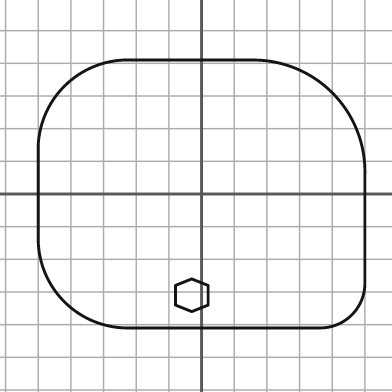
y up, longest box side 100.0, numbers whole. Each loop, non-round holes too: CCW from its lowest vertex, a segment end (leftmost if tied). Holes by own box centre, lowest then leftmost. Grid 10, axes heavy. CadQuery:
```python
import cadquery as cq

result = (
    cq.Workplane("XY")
    .moveTo(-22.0, -41.0)
    .lineTo(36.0, -41.0)
    .threePointArc((46.0, -37.0), (50.0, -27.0))
    .lineTo(50.0, 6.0)
    .threePointArc((40.0, 31.0), (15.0, 41.0))
    .lineTo(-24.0, 41.0)
    .threePointArc((-42.0, 33.0), (-50.0, 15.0))
    .lineTo(-50.0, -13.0)
    .threePointArc((-42.0, -33.0), (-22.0, -41.0))
    .close()
    .moveTo(-3.0, -36.0)
    .lineTo(2.0, -34.0)
    .lineTo(2.0, -28.0)
    .lineTo(-3.0, -26.0)
    .lineTo(-8.0, -28.0)
    .lineTo(-8.0, -34.0)
    .close()
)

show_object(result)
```